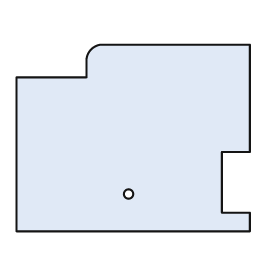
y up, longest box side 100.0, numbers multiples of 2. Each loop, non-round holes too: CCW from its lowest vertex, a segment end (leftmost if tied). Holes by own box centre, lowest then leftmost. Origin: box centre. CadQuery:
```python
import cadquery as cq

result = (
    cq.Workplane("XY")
    .moveTo(-50.0, -40.0)
    .lineTo(50.0, -40.0)
    .lineTo(50.0, -32.0)
    .lineTo(38.0, -32.0)
    .lineTo(38.0, -6.0)
    .lineTo(50.0, -6.0)
    .lineTo(50.0, 40.0)
    .lineTo(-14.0, 40.0)
    .threePointArc((-18.0, 38.0), (-20.0, 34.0))
    .lineTo(-20.0, 26.0)
    .lineTo(-50.0, 26.0)
    .close()
    .moveTo(-2.0, -24.0)
    .circle(2.0)
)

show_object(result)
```